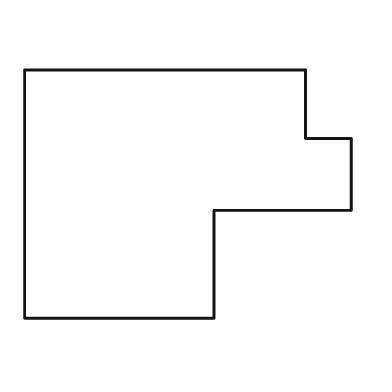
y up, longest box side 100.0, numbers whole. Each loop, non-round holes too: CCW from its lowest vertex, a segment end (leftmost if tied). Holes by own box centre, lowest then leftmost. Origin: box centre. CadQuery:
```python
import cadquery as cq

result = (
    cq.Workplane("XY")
    .moveTo(-50.0, -38.0)
    .lineTo(8.0, -38.0)
    .lineTo(8.0, -5.0)
    .lineTo(50.0, -5.0)
    .lineTo(50.0, 17.0)
    .lineTo(36.0, 17.0)
    .lineTo(36.0, 38.0)
    .lineTo(-50.0, 38.0)
    .close()
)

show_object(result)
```